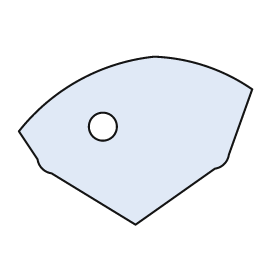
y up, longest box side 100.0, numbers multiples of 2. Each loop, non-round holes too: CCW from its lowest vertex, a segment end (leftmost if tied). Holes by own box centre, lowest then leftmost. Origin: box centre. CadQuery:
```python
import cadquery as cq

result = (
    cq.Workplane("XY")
    .moveTo(0.0, -36.0)
    .lineTo(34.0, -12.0)
    .threePointArc((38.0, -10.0), (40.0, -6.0))
    .lineTo(50.0, 22.0)
    .threePointArc((30.0, 32.0), (8.0, 36.0))
    .threePointArc((-24.0, 26.0), (-50.0, 4.0))
    .lineTo(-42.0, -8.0)
    .threePointArc((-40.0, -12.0), (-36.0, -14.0))
    .close()
    .moveTo(-14.0, 6.0)
    .circle(6.0)
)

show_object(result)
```